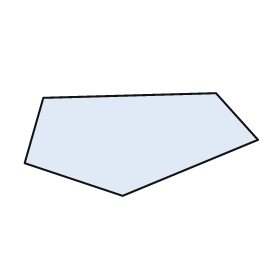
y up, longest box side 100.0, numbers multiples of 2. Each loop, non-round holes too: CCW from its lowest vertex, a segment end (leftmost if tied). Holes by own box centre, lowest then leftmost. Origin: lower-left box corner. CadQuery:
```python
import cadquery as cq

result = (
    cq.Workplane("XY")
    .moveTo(42.0, 0.0)
    .lineTo(100.0, 24.0)
    .lineTo(82.0, 44.0)
    .lineTo(8.0, 42.0)
    .lineTo(0.0, 14.0)
    .close()
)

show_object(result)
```